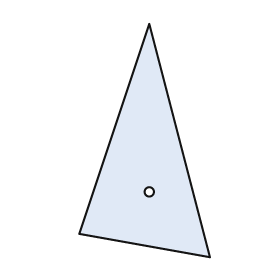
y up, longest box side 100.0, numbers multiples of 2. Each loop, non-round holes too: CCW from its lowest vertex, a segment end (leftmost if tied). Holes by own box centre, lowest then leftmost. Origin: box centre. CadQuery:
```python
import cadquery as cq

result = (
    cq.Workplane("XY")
    .moveTo(28.0, -50.0)
    .lineTo(2.0, 50.0)
    .lineTo(-28.0, -40.0)
    .close()
    .moveTo(2.0, -22.0)
    .circle(2.0)
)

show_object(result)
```